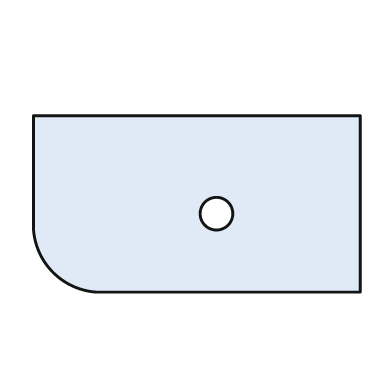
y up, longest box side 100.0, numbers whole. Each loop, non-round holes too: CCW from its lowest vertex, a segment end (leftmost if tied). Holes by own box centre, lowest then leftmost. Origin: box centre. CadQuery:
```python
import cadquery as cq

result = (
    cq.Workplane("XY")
    .moveTo(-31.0, -27.0)
    .lineTo(50.0, -27.0)
    .lineTo(50.0, 27.0)
    .lineTo(-50.0, 27.0)
    .lineTo(-50.0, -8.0)
    .threePointArc((-44.0, -21.0), (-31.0, -27.0))
    .close()
    .moveTo(6.0, -3.0)
    .circle(5.0)
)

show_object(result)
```